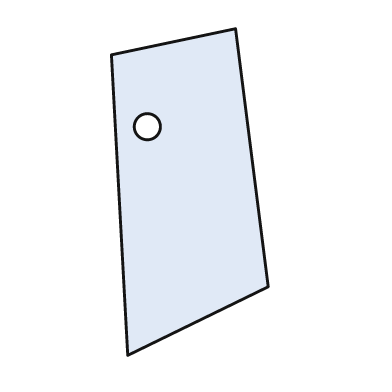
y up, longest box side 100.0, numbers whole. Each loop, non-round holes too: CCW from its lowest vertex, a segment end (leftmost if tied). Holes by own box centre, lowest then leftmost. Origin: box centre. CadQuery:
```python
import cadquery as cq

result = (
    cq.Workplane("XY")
    .moveTo(-19.0, -50.0)
    .lineTo(24.0, -29.0)
    .lineTo(14.0, 50.0)
    .lineTo(-24.0, 42.0)
    .close()
    .moveTo(-13.0, 20.0)
    .circle(4.0)
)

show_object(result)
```